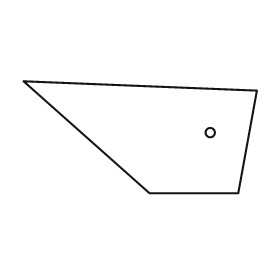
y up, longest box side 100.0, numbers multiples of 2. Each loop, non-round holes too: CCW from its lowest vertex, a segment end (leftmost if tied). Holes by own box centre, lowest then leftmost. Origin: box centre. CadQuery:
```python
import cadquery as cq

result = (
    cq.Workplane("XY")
    .moveTo(4.0, -24.0)
    .lineTo(42.0, -24.0)
    .lineTo(50.0, 20.0)
    .lineTo(-50.0, 24.0)
    .close()
    .moveTo(30.0, 2.0)
    .circle(2.0)
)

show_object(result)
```